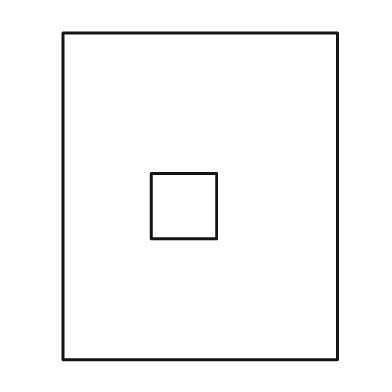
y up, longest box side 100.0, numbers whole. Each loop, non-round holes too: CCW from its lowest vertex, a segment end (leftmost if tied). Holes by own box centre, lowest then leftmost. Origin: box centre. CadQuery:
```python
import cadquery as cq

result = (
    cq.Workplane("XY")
    .moveTo(-42.0, -50.0)
    .lineTo(42.0, -50.0)
    .lineTo(42.0, 50.0)
    .lineTo(-42.0, 50.0)
    .close()
    .moveTo(-15.0, -13.0)
    .lineTo(5.0, -13.0)
    .lineTo(5.0, 7.0)
    .lineTo(-15.0, 7.0)
    .close()
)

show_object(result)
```